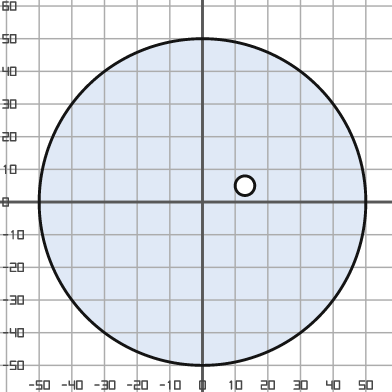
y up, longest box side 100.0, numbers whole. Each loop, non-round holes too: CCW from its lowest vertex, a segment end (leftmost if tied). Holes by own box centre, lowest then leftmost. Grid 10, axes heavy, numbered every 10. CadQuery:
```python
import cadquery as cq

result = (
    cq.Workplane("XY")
    .moveTo(0.0, 0.0)
    .circle(50.0)
    .moveTo(13.0, 5.0)
    .circle(3.0)
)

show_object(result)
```